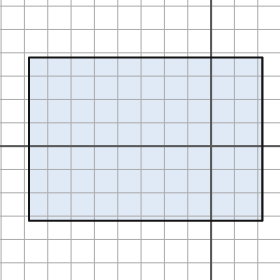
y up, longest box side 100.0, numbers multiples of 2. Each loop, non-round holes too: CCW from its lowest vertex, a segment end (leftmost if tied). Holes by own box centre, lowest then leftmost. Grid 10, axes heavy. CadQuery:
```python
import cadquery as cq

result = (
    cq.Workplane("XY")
    .moveTo(-78.0, -32.0)
    .lineTo(22.0, -32.0)
    .lineTo(22.0, 38.0)
    .lineTo(-78.0, 38.0)
    .close()
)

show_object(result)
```